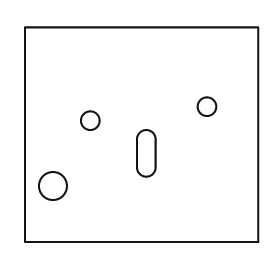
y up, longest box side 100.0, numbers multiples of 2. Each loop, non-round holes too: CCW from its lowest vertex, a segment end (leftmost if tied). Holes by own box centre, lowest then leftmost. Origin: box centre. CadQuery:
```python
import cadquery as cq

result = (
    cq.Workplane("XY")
    .moveTo(-50.0, -46.0)
    .lineTo(50.0, -46.0)
    .lineTo(50.0, 46.0)
    .lineTo(-50.0, 46.0)
    .close()
    .moveTo(-38.0, -22.0)
    .circle(6.0)
    .moveTo(-2.0, -14.0)
    .threePointArc((2.0, -18.0), (6.0, -14.0))
    .lineTo(6.0, -2.0)
    .threePointArc((2.0, 2.0), (-2.0, -2.0))
    .close()
    .moveTo(-22.0, 6.0)
    .circle(4.0)
    .moveTo(28.0, 12.0)
    .circle(4.0)
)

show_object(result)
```